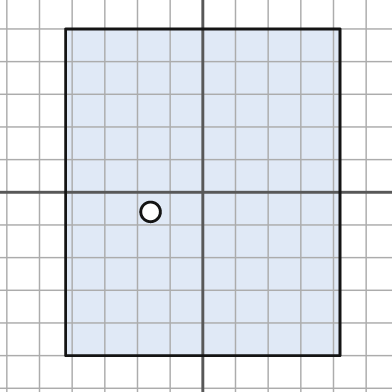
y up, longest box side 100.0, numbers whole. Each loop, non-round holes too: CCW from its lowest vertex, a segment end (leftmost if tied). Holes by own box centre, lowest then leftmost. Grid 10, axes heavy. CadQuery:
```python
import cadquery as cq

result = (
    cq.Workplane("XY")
    .moveTo(-42.0, -50.0)
    .lineTo(42.0, -50.0)
    .lineTo(42.0, 50.0)
    .lineTo(-42.0, 50.0)
    .close()
    .moveTo(-16.0, -6.0)
    .circle(3.0)
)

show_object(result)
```